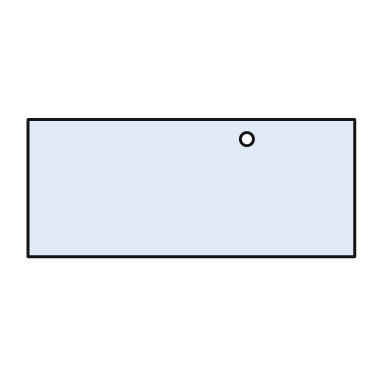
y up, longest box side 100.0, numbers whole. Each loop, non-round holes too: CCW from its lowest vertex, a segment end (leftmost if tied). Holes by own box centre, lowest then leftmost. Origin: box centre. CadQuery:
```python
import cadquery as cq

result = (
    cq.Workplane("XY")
    .moveTo(-50.0, -21.0)
    .lineTo(50.0, -21.0)
    .lineTo(50.0, 21.0)
    .lineTo(-50.0, 21.0)
    .close()
    .moveTo(17.0, 15.0)
    .circle(2.0)
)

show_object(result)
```